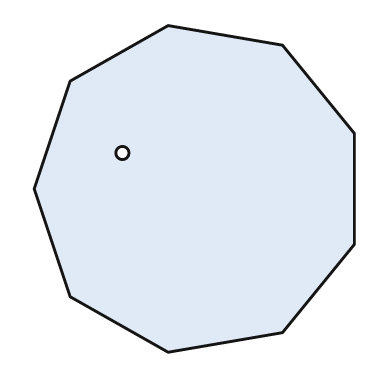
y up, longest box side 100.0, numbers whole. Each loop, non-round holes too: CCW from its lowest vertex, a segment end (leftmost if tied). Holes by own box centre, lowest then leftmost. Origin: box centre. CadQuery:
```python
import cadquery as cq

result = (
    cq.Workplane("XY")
    .moveTo(-8.0, -50.0)
    .lineTo(27.0, -44.0)
    .lineTo(49.0, -17.0)
    .lineTo(49.0, 17.0)
    .lineTo(27.0, 44.0)
    .lineTo(-8.0, 50.0)
    .lineTo(-38.0, 33.0)
    .lineTo(-49.0, 0.0)
    .lineTo(-38.0, -33.0)
    .close()
    .moveTo(-22.0, 11.0)
    .circle(2.0)
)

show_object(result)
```